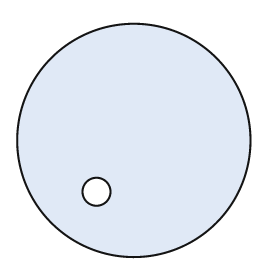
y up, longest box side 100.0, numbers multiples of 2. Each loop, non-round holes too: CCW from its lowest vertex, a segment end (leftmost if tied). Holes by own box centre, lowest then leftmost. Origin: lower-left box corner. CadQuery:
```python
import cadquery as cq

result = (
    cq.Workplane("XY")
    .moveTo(50.0, 50.0)
    .circle(50.0)
    .moveTo(34.0, 28.0)
    .circle(6.0)
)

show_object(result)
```